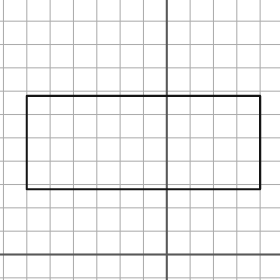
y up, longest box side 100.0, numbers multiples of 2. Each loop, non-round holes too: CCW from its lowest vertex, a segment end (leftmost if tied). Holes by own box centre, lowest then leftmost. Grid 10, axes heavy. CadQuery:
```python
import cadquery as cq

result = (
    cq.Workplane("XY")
    .moveTo(-60.0, 28.0)
    .lineTo(40.0, 28.0)
    .lineTo(40.0, 68.0)
    .lineTo(-60.0, 68.0)
    .close()
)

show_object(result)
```